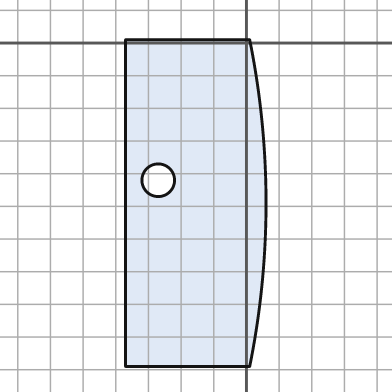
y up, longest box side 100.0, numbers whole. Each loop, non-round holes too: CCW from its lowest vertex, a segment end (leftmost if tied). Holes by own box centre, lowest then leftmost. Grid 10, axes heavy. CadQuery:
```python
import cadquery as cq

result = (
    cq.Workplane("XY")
    .moveTo(-37.0, -99.0)
    .lineTo(1.0, -99.0)
    .threePointArc((6.0, -49.0), (1.0, 1.0))
    .lineTo(-37.0, 1.0)
    .close()
    .moveTo(-27.0, -42.0)
    .circle(5.0)
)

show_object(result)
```